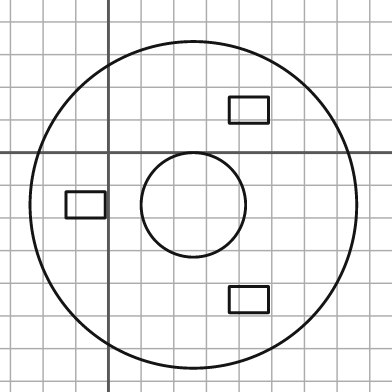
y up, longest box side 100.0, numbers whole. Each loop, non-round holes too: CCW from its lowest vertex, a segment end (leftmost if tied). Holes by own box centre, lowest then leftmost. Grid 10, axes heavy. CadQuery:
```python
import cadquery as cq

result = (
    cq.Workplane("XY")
    .moveTo(26.0, -16.0)
    .circle(50.0)
    .moveTo(37.0, -49.0)
    .lineTo(49.0, -49.0)
    .lineTo(49.0, -41.0)
    .lineTo(37.0, -41.0)
    .close()
    .moveTo(-13.0, -20.0)
    .lineTo(-1.0, -20.0)
    .lineTo(-1.0, -12.0)
    .lineTo(-13.0, -12.0)
    .close()
    .moveTo(26.0, -16.0)
    .circle(16.0)
    .moveTo(37.0, 9.0)
    .lineTo(49.0, 9.0)
    .lineTo(49.0, 17.0)
    .lineTo(37.0, 17.0)
    .close()
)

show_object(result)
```